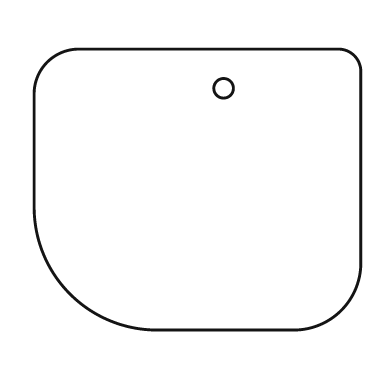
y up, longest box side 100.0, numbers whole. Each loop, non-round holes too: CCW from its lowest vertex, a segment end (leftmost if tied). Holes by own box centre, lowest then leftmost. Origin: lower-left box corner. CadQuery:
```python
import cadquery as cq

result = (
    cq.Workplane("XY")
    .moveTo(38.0, 0.0)
    .lineTo(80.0, 0.0)
    .threePointArc((94.0, 6.0), (100.0, 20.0))
    .lineTo(100.0, 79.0)
    .threePointArc((98.0, 84.0), (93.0, 86.0))
    .lineTo(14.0, 86.0)
    .threePointArc((4.0, 82.0), (0.0, 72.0))
    .lineTo(0.0, 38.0)
    .threePointArc((11.0, 11.0), (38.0, 0.0))
    .close()
    .moveTo(58.0, 74.0)
    .circle(3.0)
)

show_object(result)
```